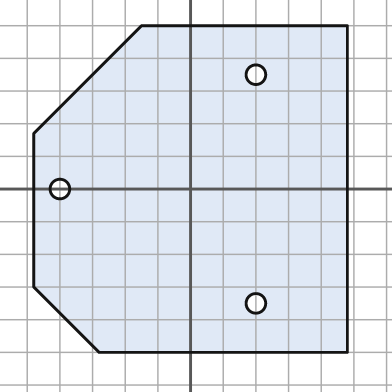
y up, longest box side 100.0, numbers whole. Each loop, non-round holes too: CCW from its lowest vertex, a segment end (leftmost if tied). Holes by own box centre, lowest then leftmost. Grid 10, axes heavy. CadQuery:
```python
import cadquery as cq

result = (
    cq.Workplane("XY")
    .moveTo(-28.0, -50.0)
    .lineTo(48.0, -50.0)
    .lineTo(48.0, 50.0)
    .lineTo(-15.0, 50.0)
    .lineTo(-48.0, 17.0)
    .lineTo(-48.0, -30.0)
    .close()
    .moveTo(20.0, -35.0)
    .circle(3.0)
    .moveTo(-40.0, 0.0)
    .circle(3.0)
    .moveTo(20.0, 35.0)
    .circle(3.0)
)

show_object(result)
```